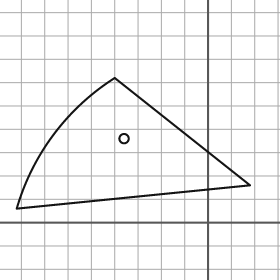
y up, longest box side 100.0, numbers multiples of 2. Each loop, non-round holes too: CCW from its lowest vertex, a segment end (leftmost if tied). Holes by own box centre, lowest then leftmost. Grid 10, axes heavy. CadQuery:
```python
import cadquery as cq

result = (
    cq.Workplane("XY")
    .moveTo(-82.0, 6.0)
    .lineTo(18.0, 16.0)
    .lineTo(-40.0, 62.0)
    .threePointArc((-66.0, 38.0), (-82.0, 6.0))
    .close()
    .moveTo(-36.0, 36.0)
    .circle(2.0)
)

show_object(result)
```